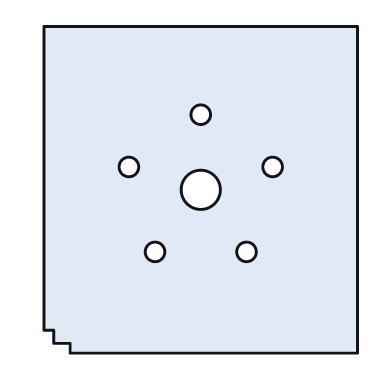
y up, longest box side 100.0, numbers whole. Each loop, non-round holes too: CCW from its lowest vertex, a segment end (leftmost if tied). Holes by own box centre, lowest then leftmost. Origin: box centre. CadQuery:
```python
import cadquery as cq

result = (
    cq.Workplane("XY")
    .moveTo(-40.0, -50.0)
    .lineTo(48.0, -50.0)
    .lineTo(48.0, 50.0)
    .lineTo(-48.0, 50.0)
    .lineTo(-48.0, -43.0)
    .lineTo(-45.0, -43.0)
    .lineTo(-45.0, -47.0)
    .lineTo(-40.0, -47.0)
    .close()
    .moveTo(-14.0, -19.0)
    .circle(3.0)
    .moveTo(14.0, -19.0)
    .circle(3.0)
    .moveTo(0.0, 0.0)
    .circle(6.0)
    .moveTo(-22.0, 7.0)
    .circle(3.0)
    .moveTo(22.0, 7.0)
    .circle(3.0)
    .moveTo(0.0, 23.0)
    .circle(3.0)
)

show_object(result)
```